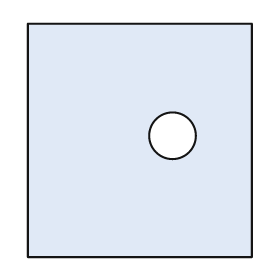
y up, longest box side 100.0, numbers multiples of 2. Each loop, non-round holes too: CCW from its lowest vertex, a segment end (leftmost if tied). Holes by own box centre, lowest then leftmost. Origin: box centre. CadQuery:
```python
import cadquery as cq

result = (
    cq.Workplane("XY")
    .moveTo(-48.0, -50.0)
    .lineTo(48.0, -50.0)
    .lineTo(48.0, 50.0)
    .lineTo(-48.0, 50.0)
    .close()
    .moveTo(14.0, 2.0)
    .circle(10.0)
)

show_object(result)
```